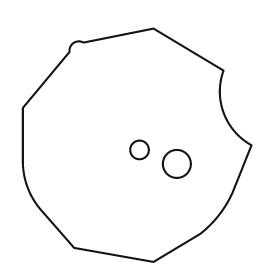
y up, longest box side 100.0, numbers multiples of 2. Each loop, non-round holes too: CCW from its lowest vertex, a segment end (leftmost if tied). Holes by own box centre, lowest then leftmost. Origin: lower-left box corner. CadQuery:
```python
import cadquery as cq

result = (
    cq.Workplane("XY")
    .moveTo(56.0, 0.0)
    .lineTo(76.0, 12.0)
    .threePointArc((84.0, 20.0), (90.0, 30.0))
    .lineTo(98.0, 50.0)
    .threePointArc((86.0, 64.0), (86.0, 82.0))
    .lineTo(56.0, 100.0)
    .lineTo(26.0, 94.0)
    .threePointArc((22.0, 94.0), (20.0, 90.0))
    .lineTo(0.0, 66.0)
    .lineTo(0.0, 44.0)
    .threePointArc((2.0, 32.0), (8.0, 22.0))
    .lineTo(22.0, 6.0)
    .close()
    .moveTo(66.0, 42.0)
    .circle(6.0)
    .moveTo(50.0, 48.0)
    .circle(4.0)
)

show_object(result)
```